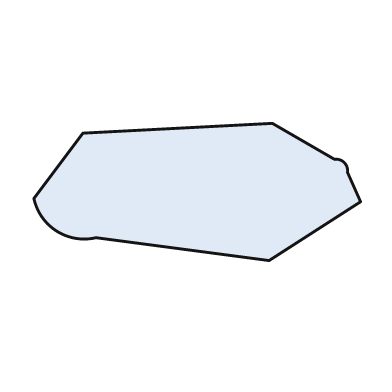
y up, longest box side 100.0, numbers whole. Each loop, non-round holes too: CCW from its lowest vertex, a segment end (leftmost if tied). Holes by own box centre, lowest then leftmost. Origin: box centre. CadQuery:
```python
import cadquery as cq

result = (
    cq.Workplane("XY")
    .moveTo(22.0, -21.0)
    .lineTo(50.0, -3.0)
    .lineTo(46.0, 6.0)
    .threePointArc((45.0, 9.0), (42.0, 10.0))
    .lineTo(23.0, 21.0)
    .lineTo(-35.0, 18.0)
    .lineTo(-50.0, -2.0)
    .threePointArc((-43.0, -12.0), (-31.0, -14.0))
    .close()
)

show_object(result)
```